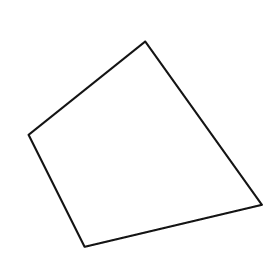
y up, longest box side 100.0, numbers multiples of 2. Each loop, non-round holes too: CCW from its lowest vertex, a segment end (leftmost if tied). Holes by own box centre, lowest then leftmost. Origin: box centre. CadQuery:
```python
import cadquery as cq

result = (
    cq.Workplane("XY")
    .moveTo(-26.0, -44.0)
    .lineTo(50.0, -26.0)
    .lineTo(0.0, 44.0)
    .lineTo(-50.0, 4.0)
    .close()
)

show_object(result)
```